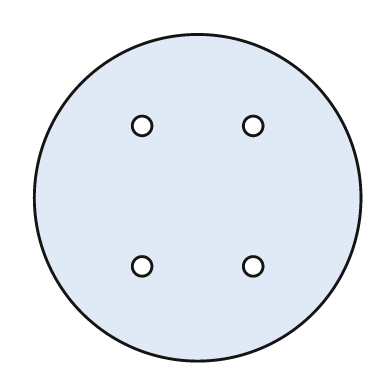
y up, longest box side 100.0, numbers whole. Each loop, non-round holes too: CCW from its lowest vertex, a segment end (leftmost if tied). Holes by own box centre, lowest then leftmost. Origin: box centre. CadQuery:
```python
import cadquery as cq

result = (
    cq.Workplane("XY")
    .moveTo(0.0, 0.0)
    .circle(50.0)
    .moveTo(-17.0, -21.0)
    .circle(3.0)
    .moveTo(17.0, -21.0)
    .circle(3.0)
    .moveTo(-17.0, 22.0)
    .circle(3.0)
    .moveTo(17.0, 22.0)
    .circle(3.0)
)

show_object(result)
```